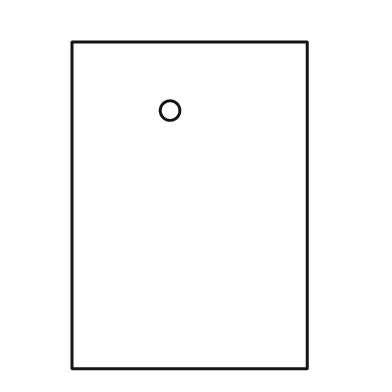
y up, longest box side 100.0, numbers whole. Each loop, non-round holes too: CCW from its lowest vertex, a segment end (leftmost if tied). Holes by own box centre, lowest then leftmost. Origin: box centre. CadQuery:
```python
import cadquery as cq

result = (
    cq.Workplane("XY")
    .moveTo(-36.0, -50.0)
    .lineTo(36.0, -50.0)
    .lineTo(36.0, 50.0)
    .lineTo(-36.0, 50.0)
    .close()
    .moveTo(-6.0, 29.0)
    .circle(3.0)
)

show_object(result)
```